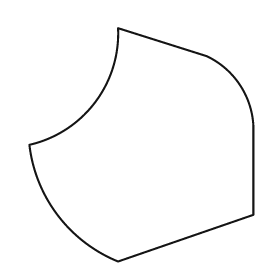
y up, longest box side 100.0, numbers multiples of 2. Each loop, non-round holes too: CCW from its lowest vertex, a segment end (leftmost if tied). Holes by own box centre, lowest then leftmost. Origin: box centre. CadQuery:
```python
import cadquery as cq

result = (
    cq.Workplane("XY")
    .moveTo(-10.0, -50.0)
    .lineTo(48.0, -30.0)
    .lineTo(48.0, 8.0)
    .threePointArc((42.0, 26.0), (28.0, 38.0))
    .lineTo(-10.0, 50.0)
    .threePointArc((-20.0, 18.0), (-48.0, 0.0))
    .threePointArc((-36.0, -30.0), (-10.0, -50.0))
    .close()
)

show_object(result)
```